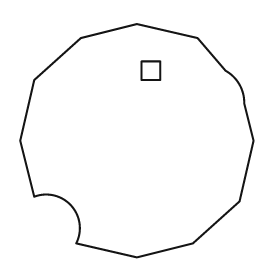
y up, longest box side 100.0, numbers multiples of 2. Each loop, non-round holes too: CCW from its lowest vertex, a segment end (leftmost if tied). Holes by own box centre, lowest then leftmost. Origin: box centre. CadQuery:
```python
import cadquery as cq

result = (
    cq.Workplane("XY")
    .moveTo(0.0, -50.0)
    .lineTo(24.0, -44.0)
    .lineTo(44.0, -26.0)
    .lineTo(50.0, 0.0)
    .lineTo(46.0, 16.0)
    .threePointArc((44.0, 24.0), (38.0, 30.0))
    .lineTo(26.0, 44.0)
    .lineTo(0.0, 50.0)
    .lineTo(-24.0, 44.0)
    .lineTo(-44.0, 26.0)
    .lineTo(-50.0, 0.0)
    .lineTo(-44.0, -24.0)
    .threePointArc((-28.0, -28.0), (-26.0, -44.0))
    .close()
    .moveTo(2.0, 26.0)
    .lineTo(10.0, 26.0)
    .lineTo(10.0, 34.0)
    .lineTo(2.0, 34.0)
    .close()
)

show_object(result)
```